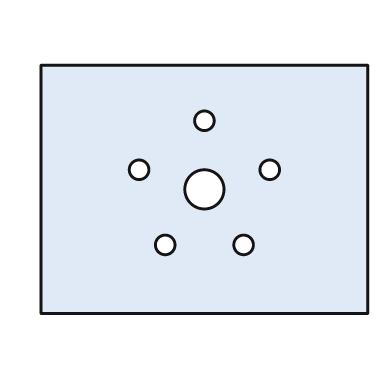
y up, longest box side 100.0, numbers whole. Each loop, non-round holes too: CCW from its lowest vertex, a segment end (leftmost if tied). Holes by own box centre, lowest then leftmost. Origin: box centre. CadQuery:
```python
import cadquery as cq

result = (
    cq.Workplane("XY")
    .moveTo(-50.0, -38.0)
    .lineTo(50.0, -38.0)
    .lineTo(50.0, 38.0)
    .lineTo(-50.0, 38.0)
    .close()
    .moveTo(-12.0, -17.0)
    .circle(3.0)
    .moveTo(12.0, -17.0)
    .circle(3.0)
    .moveTo(0.0, 0.0)
    .circle(6.0)
    .moveTo(-20.0, 6.0)
    .circle(3.0)
    .moveTo(20.0, 6.0)
    .circle(3.0)
    .moveTo(0.0, 21.0)
    .circle(3.0)
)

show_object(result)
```